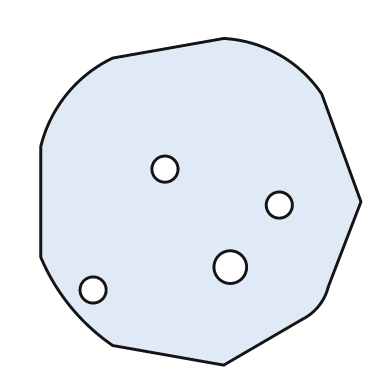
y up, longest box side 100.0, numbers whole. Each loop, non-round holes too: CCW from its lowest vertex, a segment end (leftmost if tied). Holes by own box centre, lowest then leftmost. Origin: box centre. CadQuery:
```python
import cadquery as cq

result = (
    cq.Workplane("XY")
    .moveTo(7.0, -50.0)
    .lineTo(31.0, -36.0)
    .threePointArc((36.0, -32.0), (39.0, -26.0))
    .lineTo(49.0, 0.0)
    .lineTo(37.0, 33.0)
    .threePointArc((24.0, 45.0), (7.0, 50.0))
    .lineTo(-27.0, 44.0)
    .threePointArc((-41.0, 33.0), (-49.0, 17.0))
    .lineTo(-49.0, -17.0)
    .threePointArc((-40.0, -32.0), (-27.0, -44.0))
    .close()
    .moveTo(-33.0, -27.0)
    .circle(4.0)
    .moveTo(9.0, -20.0)
    .circle(5.0)
    .moveTo(24.0, -1.0)
    .circle(4.0)
    .moveTo(-11.0, 10.0)
    .circle(4.0)
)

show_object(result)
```